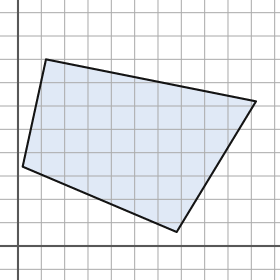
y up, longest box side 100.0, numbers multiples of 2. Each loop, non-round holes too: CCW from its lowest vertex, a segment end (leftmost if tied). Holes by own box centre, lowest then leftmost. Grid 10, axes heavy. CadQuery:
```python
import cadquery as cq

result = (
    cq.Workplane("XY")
    .moveTo(68.0, 6.0)
    .lineTo(102.0, 62.0)
    .lineTo(12.0, 80.0)
    .lineTo(2.0, 34.0)
    .close()
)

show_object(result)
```